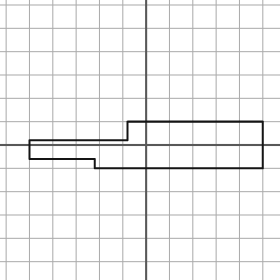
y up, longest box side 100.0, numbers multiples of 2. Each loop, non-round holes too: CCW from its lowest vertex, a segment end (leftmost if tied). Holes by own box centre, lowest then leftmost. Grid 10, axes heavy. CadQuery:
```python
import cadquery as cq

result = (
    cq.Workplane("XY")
    .moveTo(-22.0, -10.0)
    .lineTo(50.0, -10.0)
    .lineTo(50.0, 10.0)
    .lineTo(-8.0, 10.0)
    .lineTo(-8.0, 2.0)
    .lineTo(-50.0, 2.0)
    .lineTo(-50.0, -6.0)
    .lineTo(-22.0, -6.0)
    .close()
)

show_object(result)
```